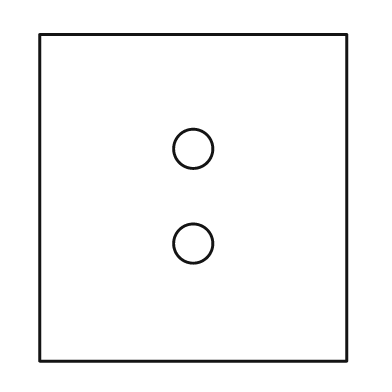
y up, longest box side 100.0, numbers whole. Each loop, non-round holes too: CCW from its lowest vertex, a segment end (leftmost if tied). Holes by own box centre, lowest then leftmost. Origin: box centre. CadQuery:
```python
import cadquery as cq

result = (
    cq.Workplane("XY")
    .moveTo(-47.0, -50.0)
    .lineTo(47.0, -50.0)
    .lineTo(47.0, 50.0)
    .lineTo(-47.0, 50.0)
    .close()
    .moveTo(0.0, -14.0)
    .circle(6.0)
    .moveTo(0.0, 15.0)
    .circle(6.0)
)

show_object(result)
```